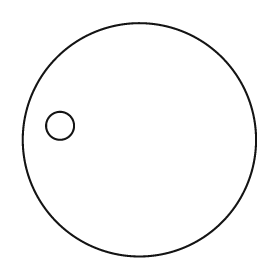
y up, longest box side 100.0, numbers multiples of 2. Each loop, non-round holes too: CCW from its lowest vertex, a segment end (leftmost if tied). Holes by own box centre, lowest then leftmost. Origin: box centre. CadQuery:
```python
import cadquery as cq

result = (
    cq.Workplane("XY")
    .moveTo(0.0, 0.0)
    .circle(50.0)
    .moveTo(-34.0, 6.0)
    .circle(6.0)
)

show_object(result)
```